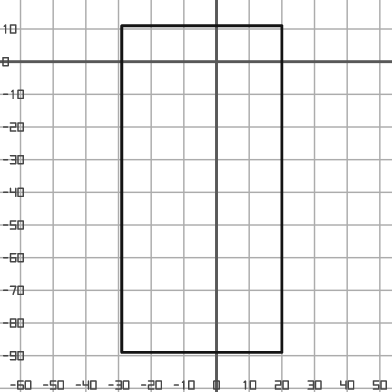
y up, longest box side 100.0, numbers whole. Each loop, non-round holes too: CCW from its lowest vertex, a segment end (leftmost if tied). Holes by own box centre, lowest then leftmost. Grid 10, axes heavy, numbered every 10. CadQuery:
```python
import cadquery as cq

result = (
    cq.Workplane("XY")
    .moveTo(-29.0, -89.0)
    .lineTo(20.0, -89.0)
    .lineTo(20.0, 11.0)
    .lineTo(-29.0, 11.0)
    .close()
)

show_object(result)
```